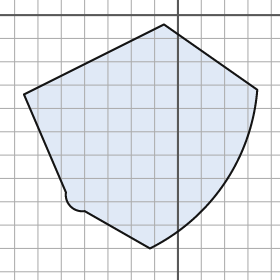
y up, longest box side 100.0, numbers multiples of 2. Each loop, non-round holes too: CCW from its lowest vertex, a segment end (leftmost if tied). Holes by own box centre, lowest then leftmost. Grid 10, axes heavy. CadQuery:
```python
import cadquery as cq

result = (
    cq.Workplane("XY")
    .moveTo(-12.0, -100.0)
    .threePointArc((20.0, -72.0), (34.0, -32.0))
    .lineTo(-6.0, -4.0)
    .lineTo(-66.0, -34.0)
    .lineTo(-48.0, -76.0)
    .threePointArc((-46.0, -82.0), (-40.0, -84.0))
    .close()
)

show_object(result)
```